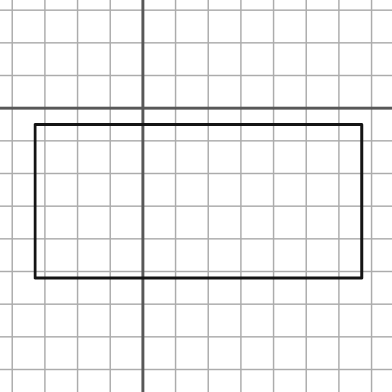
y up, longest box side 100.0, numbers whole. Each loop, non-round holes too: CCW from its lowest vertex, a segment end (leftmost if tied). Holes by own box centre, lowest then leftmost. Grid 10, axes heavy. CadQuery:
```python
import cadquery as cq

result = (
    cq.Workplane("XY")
    .moveTo(-33.0, -52.0)
    .lineTo(67.0, -52.0)
    .lineTo(67.0, -5.0)
    .lineTo(-33.0, -5.0)
    .close()
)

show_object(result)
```